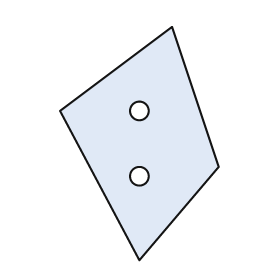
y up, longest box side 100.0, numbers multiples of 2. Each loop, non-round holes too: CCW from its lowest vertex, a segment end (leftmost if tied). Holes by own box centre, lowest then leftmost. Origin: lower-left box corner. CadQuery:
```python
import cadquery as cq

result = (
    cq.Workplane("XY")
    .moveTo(34.0, 0.0)
    .lineTo(68.0, 40.0)
    .lineTo(48.0, 100.0)
    .lineTo(0.0, 64.0)
    .close()
    .moveTo(34.0, 36.0)
    .circle(4.0)
    .moveTo(34.0, 64.0)
    .circle(4.0)
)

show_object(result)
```